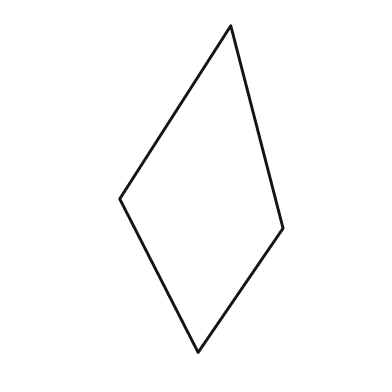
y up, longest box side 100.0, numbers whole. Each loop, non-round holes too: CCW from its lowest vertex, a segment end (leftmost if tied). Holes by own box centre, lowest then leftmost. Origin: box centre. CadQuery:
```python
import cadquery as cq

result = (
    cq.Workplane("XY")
    .moveTo(-1.0, -50.0)
    .lineTo(25.0, -12.0)
    .lineTo(9.0, 50.0)
    .lineTo(-25.0, -3.0)
    .close()
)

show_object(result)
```